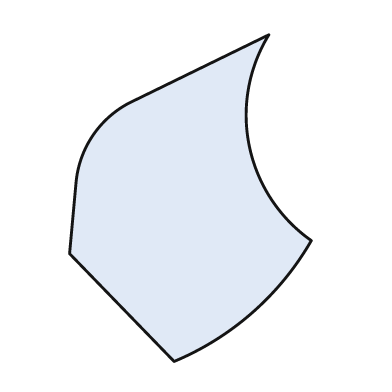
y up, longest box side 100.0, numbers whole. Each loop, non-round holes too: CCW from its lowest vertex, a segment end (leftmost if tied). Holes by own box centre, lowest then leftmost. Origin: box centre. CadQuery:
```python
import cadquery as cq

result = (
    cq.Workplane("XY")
    .moveTo(-5.0, -50.0)
    .threePointArc((19.0, -35.0), (37.0, -13.0))
    .threePointArc((18.0, 16.0), (24.0, 50.0))
    .lineTo(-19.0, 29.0)
    .threePointArc((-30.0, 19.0), (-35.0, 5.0))
    .lineTo(-37.0, -17.0)
    .close()
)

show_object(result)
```